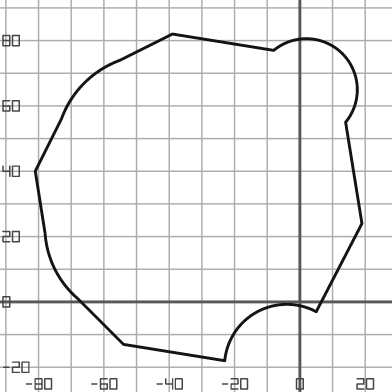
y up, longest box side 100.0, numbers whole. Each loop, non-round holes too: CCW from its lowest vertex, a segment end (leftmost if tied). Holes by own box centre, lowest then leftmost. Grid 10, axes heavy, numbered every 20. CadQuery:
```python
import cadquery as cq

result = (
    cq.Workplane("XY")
    .moveTo(-23.0, -18.0)
    .threePointArc((-13.0, -3.0), (5.0, -3.0))
    .lineTo(19.0, 24.0)
    .lineTo(14.0, 55.0)
    .threePointArc((13.0, 76.0), (-8.0, 77.0))
    .lineTo(-39.0, 82.0)
    .lineTo(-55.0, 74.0)
    .threePointArc((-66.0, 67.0), (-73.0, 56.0))
    .lineTo(-81.0, 40.0)
    .lineTo(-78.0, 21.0)
    .threePointArc((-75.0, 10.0), (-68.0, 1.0))
    .lineTo(-54.0, -13.0)
    .close()
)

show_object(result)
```